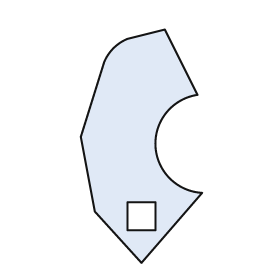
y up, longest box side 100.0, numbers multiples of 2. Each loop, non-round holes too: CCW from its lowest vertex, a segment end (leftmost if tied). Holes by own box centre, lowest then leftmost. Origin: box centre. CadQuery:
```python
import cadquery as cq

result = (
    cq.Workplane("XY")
    .moveTo(0.0, -50.0)
    .lineTo(26.0, -20.0)
    .threePointArc((6.0, 0.0), (24.0, 22.0))
    .lineTo(10.0, 50.0)
    .lineTo(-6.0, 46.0)
    .threePointArc((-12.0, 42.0), (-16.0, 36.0))
    .lineTo(-26.0, 4.0)
    .lineTo(-20.0, -28.0)
    .close()
    .moveTo(-6.0, -36.0)
    .lineTo(6.0, -36.0)
    .lineTo(6.0, -24.0)
    .lineTo(-6.0, -24.0)
    .close()
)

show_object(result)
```